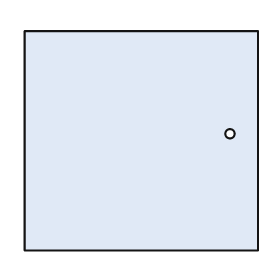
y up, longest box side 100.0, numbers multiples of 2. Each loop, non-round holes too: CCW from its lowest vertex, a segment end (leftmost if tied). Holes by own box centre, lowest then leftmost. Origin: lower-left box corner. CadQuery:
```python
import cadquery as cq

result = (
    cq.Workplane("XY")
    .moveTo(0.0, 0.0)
    .lineTo(100.0, 0.0)
    .lineTo(100.0, 94.0)
    .lineTo(0.0, 94.0)
    .close()
    .moveTo(88.0, 50.0)
    .circle(2.0)
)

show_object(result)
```